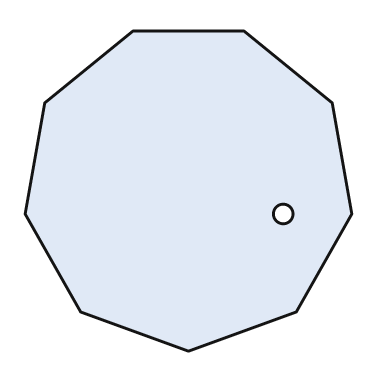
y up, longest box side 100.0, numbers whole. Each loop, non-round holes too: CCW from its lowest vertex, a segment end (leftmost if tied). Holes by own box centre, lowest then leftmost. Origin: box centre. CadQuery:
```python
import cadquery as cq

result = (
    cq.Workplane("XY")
    .moveTo(0.0, -49.0)
    .lineTo(33.0, -37.0)
    .lineTo(50.0, -7.0)
    .lineTo(44.0, 27.0)
    .lineTo(17.0, 49.0)
    .lineTo(-17.0, 49.0)
    .lineTo(-44.0, 27.0)
    .lineTo(-50.0, -7.0)
    .lineTo(-33.0, -37.0)
    .close()
    .moveTo(29.0, -7.0)
    .circle(3.0)
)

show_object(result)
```